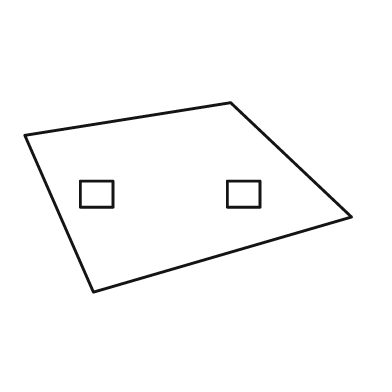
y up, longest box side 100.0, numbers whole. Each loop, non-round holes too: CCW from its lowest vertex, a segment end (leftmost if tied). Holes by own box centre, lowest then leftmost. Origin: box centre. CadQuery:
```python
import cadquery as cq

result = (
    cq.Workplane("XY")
    .moveTo(-29.0, -29.0)
    .lineTo(50.0, -6.0)
    .lineTo(13.0, 29.0)
    .lineTo(-50.0, 19.0)
    .close()
    .moveTo(-33.0, -3.0)
    .lineTo(-23.0, -3.0)
    .lineTo(-23.0, 5.0)
    .lineTo(-33.0, 5.0)
    .close()
    .moveTo(12.0, -3.0)
    .lineTo(22.0, -3.0)
    .lineTo(22.0, 5.0)
    .lineTo(12.0, 5.0)
    .close()
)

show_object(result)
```